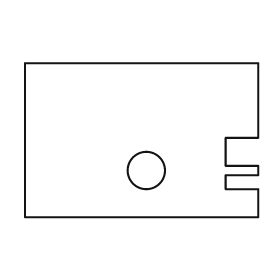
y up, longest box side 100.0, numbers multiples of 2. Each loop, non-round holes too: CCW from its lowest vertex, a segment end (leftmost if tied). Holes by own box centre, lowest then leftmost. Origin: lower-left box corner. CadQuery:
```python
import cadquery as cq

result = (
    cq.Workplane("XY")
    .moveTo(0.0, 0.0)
    .lineTo(100.0, 0.0)
    .lineTo(100.0, 12.0)
    .lineTo(86.0, 12.0)
    .lineTo(86.0, 18.0)
    .lineTo(100.0, 18.0)
    .lineTo(100.0, 22.0)
    .lineTo(86.0, 22.0)
    .lineTo(86.0, 34.0)
    .lineTo(100.0, 34.0)
    .lineTo(100.0, 66.0)
    .lineTo(0.0, 66.0)
    .close()
    .moveTo(52.0, 20.0)
    .circle(8.0)
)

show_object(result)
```